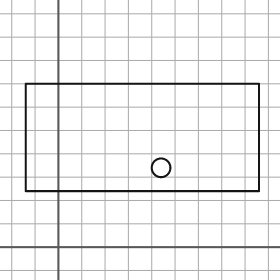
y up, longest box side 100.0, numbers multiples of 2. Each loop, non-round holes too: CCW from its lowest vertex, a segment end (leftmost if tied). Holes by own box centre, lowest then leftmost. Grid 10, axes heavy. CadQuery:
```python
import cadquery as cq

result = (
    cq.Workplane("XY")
    .moveTo(-14.0, 24.0)
    .lineTo(86.0, 24.0)
    .lineTo(86.0, 70.0)
    .lineTo(-14.0, 70.0)
    .close()
    .moveTo(44.0, 34.0)
    .circle(4.0)
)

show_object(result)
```